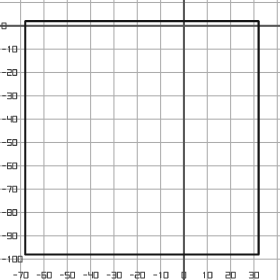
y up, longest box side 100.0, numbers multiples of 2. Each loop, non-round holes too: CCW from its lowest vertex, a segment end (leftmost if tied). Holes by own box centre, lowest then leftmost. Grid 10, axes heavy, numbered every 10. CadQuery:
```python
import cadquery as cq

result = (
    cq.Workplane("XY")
    .moveTo(-68.0, -98.0)
    .lineTo(32.0, -98.0)
    .lineTo(32.0, 2.0)
    .lineTo(-68.0, 2.0)
    .close()
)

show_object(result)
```